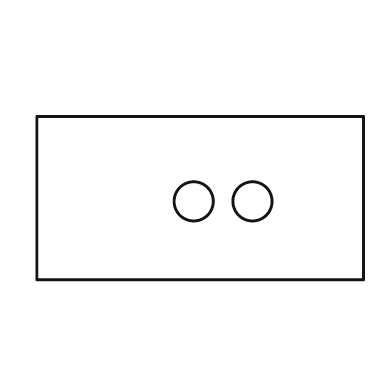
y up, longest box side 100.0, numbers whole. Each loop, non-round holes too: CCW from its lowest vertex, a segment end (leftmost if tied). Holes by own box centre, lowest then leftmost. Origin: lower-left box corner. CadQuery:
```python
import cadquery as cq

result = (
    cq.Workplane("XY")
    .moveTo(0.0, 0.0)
    .lineTo(100.0, 0.0)
    .lineTo(100.0, 50.0)
    .lineTo(0.0, 50.0)
    .close()
    .moveTo(48.0, 24.0)
    .circle(6.0)
    .moveTo(66.0, 24.0)
    .circle(6.0)
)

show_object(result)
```